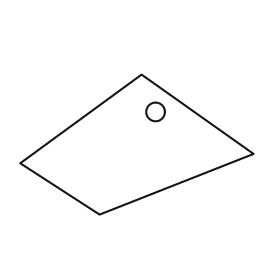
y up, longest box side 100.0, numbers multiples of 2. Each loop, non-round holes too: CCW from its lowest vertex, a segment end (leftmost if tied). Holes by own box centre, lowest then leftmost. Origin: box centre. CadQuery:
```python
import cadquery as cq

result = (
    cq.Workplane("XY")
    .moveTo(-16.0, -30.0)
    .lineTo(50.0, -4.0)
    .lineTo(2.0, 30.0)
    .lineTo(-50.0, -8.0)
    .close()
    .moveTo(8.0, 14.0)
    .circle(4.0)
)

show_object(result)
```